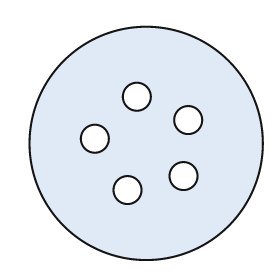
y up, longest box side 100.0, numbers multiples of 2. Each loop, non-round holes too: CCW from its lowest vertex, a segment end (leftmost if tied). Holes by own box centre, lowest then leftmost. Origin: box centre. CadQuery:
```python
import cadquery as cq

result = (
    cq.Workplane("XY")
    .moveTo(0.0, 0.0)
    .circle(50.0)
    .moveTo(-8.0, -20.0)
    .circle(6.0)
    .moveTo(16.0, -14.0)
    .circle(6.0)
    .moveTo(-22.0, 2.0)
    .circle(6.0)
    .moveTo(18.0, 10.0)
    .circle(6.0)
    .moveTo(-4.0, 20.0)
    .circle(6.0)
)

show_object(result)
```